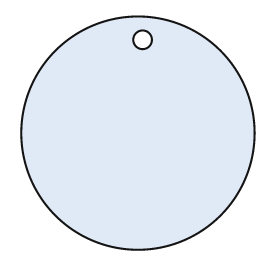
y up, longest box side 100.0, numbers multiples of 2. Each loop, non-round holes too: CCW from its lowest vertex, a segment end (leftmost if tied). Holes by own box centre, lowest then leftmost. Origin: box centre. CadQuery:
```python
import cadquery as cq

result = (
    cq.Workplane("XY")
    .moveTo(0.0, 0.0)
    .circle(50.0)
    .moveTo(2.0, 40.0)
    .circle(4.0)
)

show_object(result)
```